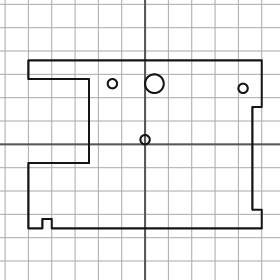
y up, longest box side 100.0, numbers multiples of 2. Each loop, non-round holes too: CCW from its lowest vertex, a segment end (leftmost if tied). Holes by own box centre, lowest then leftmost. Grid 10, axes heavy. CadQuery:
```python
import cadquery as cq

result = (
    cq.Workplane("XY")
    .moveTo(-50.0, -36.0)
    .lineTo(-44.0, -36.0)
    .lineTo(-44.0, -32.0)
    .lineTo(-40.0, -32.0)
    .lineTo(-40.0, -36.0)
    .lineTo(50.0, -36.0)
    .lineTo(50.0, -28.0)
    .lineTo(46.0, -28.0)
    .lineTo(46.0, 16.0)
    .lineTo(50.0, 16.0)
    .lineTo(50.0, 36.0)
    .lineTo(-50.0, 36.0)
    .lineTo(-50.0, 28.0)
    .lineTo(-24.0, 28.0)
    .lineTo(-24.0, -8.0)
    .lineTo(-50.0, -8.0)
    .close()
    .moveTo(0.0, 2.0)
    .circle(2.0)
    .moveTo(42.0, 24.0)
    .circle(2.0)
    .moveTo(-14.0, 26.0)
    .circle(2.0)
    .moveTo(4.0, 26.0)
    .circle(4.0)
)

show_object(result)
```